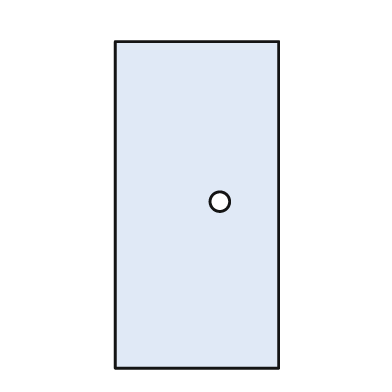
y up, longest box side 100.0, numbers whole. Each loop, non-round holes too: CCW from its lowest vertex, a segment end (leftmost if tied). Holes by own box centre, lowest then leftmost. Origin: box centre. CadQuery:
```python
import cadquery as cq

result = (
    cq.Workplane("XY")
    .moveTo(-25.0, -50.0)
    .lineTo(25.0, -50.0)
    .lineTo(25.0, 50.0)
    .lineTo(-25.0, 50.0)
    .close()
    .moveTo(7.0, 1.0)
    .circle(3.0)
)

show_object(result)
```